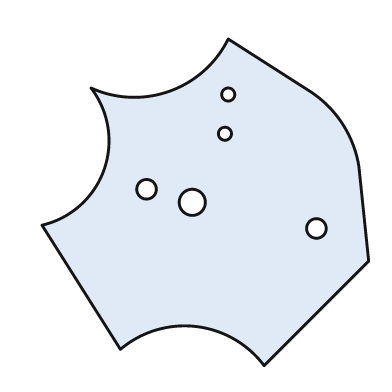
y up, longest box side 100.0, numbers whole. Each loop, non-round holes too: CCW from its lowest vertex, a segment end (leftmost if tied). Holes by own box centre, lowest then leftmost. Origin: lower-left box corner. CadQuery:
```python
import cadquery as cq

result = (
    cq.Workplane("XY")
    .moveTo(68.0, 0.0)
    .lineTo(100.0, 32.0)
    .lineTo(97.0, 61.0)
    .threePointArc((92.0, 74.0), (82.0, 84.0))
    .lineTo(57.0, 100.0)
    .threePointArc((39.0, 84.0), (15.0, 85.0))
    .threePointArc((19.0, 60.0), (0.0, 43.0))
    .lineTo(24.0, 5.0)
    .threePointArc((47.0, 12.0), (68.0, 0.0))
    .close()
    .moveTo(84.0, 42.0)
    .circle(3.0)
    .moveTo(46.0, 50.0)
    .circle(4.0)
    .moveTo(32.0, 54.0)
    .circle(3.0)
    .moveTo(56.0, 71.0)
    .circle(2.0)
    .moveTo(57.0, 83.0)
    .circle(2.0)
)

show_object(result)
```